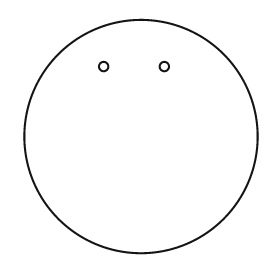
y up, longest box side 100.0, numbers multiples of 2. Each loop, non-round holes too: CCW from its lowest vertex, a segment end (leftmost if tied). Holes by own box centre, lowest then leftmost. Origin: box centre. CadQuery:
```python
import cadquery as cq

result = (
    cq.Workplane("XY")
    .moveTo(0.0, 0.0)
    .circle(50.0)
    .moveTo(-16.0, 30.0)
    .circle(2.0)
    .moveTo(10.0, 30.0)
    .circle(2.0)
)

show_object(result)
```